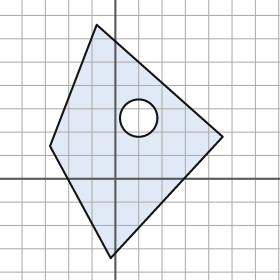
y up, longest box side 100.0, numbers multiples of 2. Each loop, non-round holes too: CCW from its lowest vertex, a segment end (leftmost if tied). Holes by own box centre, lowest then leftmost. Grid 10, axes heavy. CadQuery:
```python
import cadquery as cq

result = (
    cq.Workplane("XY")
    .moveTo(-2.0, -34.0)
    .lineTo(46.0, 18.0)
    .lineTo(-8.0, 66.0)
    .lineTo(-28.0, 14.0)
    .close()
    .moveTo(10.0, 26.0)
    .circle(8.0)
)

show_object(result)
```